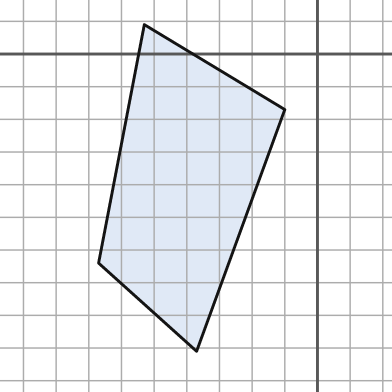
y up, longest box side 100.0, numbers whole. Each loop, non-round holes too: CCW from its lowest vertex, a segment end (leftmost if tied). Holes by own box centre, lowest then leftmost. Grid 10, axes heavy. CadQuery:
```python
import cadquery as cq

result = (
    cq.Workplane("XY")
    .moveTo(-37.0, -91.0)
    .lineTo(-10.0, -17.0)
    .lineTo(-53.0, 9.0)
    .lineTo(-67.0, -64.0)
    .close()
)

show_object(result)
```